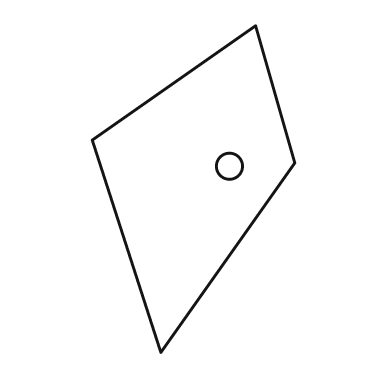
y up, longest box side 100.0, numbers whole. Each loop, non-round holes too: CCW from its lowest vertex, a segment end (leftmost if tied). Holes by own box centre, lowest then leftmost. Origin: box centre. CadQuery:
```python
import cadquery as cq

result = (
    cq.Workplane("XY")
    .moveTo(-10.0, -50.0)
    .lineTo(31.0, 8.0)
    .lineTo(19.0, 50.0)
    .lineTo(-31.0, 15.0)
    .close()
    .moveTo(11.0, 7.0)
    .circle(4.0)
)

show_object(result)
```